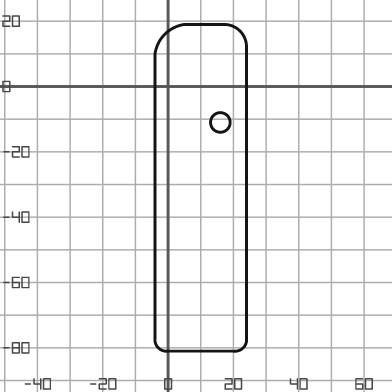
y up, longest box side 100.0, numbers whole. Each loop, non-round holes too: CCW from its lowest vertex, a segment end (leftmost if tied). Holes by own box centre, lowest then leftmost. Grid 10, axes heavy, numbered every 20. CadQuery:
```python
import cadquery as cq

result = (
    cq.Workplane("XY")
    .moveTo(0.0, -81.0)
    .lineTo(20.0, -81.0)
    .threePointArc((23.0, -80.0), (24.0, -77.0))
    .lineTo(24.0, 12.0)
    .threePointArc((22.0, 17.0), (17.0, 19.0))
    .lineTo(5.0, 19.0)
    .threePointArc((-1.0, 16.0), (-4.0, 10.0))
    .lineTo(-4.0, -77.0)
    .threePointArc((-3.0, -80.0), (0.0, -81.0))
    .close()
    .moveTo(16.0, -11.0)
    .circle(3.0)
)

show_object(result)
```